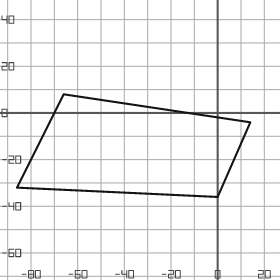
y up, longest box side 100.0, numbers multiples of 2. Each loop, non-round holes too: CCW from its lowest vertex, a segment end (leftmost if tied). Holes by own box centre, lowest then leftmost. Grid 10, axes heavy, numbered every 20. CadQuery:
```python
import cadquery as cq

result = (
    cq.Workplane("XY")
    .moveTo(0.0, -36.0)
    .lineTo(14.0, -4.0)
    .lineTo(-66.0, 8.0)
    .lineTo(-86.0, -32.0)
    .close()
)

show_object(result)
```